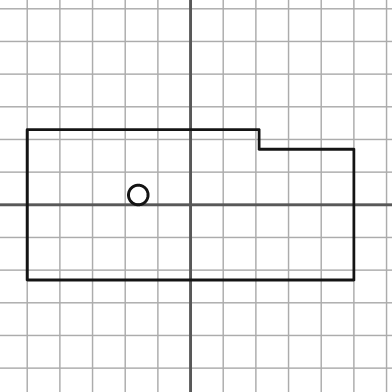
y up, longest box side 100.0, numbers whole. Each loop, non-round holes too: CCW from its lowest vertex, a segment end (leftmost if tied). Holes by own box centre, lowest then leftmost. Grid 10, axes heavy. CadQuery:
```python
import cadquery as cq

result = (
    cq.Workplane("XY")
    .moveTo(-50.0, -23.0)
    .lineTo(50.0, -23.0)
    .lineTo(50.0, 17.0)
    .lineTo(21.0, 17.0)
    .lineTo(21.0, 23.0)
    .lineTo(-50.0, 23.0)
    .close()
    .moveTo(-16.0, 3.0)
    .circle(3.0)
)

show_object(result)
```